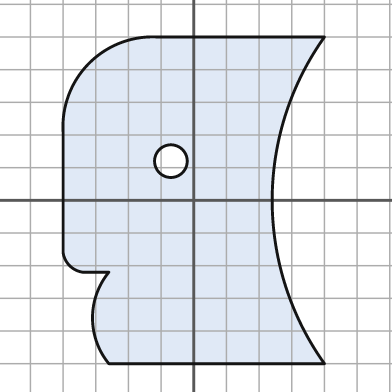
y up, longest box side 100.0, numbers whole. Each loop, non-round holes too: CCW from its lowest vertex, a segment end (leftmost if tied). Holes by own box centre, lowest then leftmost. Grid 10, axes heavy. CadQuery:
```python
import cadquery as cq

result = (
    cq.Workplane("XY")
    .moveTo(-26.0, -50.0)
    .lineTo(40.0, -50.0)
    .threePointArc((24.0, 0.0), (40.0, 50.0))
    .lineTo(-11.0, 50.0)
    .threePointArc((-32.0, 42.0), (-40.0, 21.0))
    .lineTo(-40.0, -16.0)
    .threePointArc((-38.0, -20.0), (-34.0, -22.0))
    .lineTo(-26.0, -22.0)
    .threePointArc((-31.0, -36.0), (-26.0, -50.0))
    .close()
    .moveTo(-7.0, 12.0)
    .circle(5.0)
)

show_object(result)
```